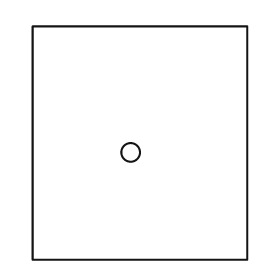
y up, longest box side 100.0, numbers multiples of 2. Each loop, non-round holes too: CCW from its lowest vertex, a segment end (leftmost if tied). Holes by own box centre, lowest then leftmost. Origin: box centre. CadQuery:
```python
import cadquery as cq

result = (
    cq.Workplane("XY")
    .moveTo(-46.0, -50.0)
    .lineTo(46.0, -50.0)
    .lineTo(46.0, 50.0)
    .lineTo(-46.0, 50.0)
    .close()
    .moveTo(-4.0, -4.0)
    .circle(4.0)
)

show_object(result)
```